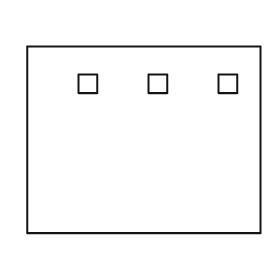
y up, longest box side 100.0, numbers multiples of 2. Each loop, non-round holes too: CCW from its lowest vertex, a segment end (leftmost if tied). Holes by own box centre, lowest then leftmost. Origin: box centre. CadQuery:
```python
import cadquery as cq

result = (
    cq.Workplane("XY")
    .moveTo(-50.0, -40.0)
    .lineTo(50.0, -40.0)
    .lineTo(50.0, 40.0)
    .lineTo(-50.0, 40.0)
    .close()
    .moveTo(-28.0, 20.0)
    .lineTo(-20.0, 20.0)
    .lineTo(-20.0, 28.0)
    .lineTo(-28.0, 28.0)
    .close()
    .moveTo(2.0, 20.0)
    .lineTo(10.0, 20.0)
    .lineTo(10.0, 28.0)
    .lineTo(2.0, 28.0)
    .close()
    .moveTo(32.0, 20.0)
    .lineTo(40.0, 20.0)
    .lineTo(40.0, 28.0)
    .lineTo(32.0, 28.0)
    .close()
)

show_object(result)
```